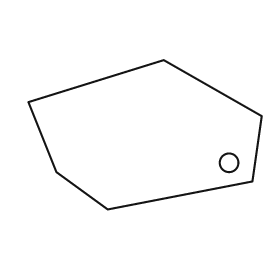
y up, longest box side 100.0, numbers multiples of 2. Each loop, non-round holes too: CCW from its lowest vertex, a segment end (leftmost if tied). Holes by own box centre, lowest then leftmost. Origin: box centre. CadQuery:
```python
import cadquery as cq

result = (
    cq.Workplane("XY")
    .moveTo(-16.0, -32.0)
    .lineTo(46.0, -20.0)
    .lineTo(50.0, 8.0)
    .lineTo(8.0, 32.0)
    .lineTo(-50.0, 14.0)
    .lineTo(-38.0, -16.0)
    .close()
    .moveTo(36.0, -12.0)
    .circle(4.0)
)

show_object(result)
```